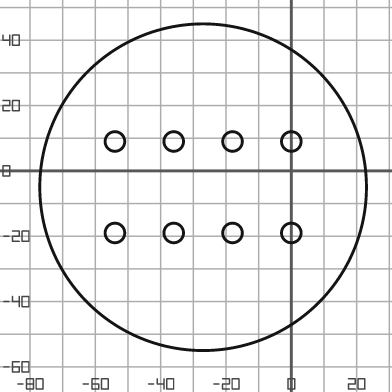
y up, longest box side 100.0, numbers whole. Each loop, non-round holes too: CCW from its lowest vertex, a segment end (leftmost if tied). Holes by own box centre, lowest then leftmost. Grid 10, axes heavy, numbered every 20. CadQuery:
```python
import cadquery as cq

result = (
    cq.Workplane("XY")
    .moveTo(-27.0, -5.0)
    .circle(50.0)
    .moveTo(-54.0, -19.0)
    .circle(3.0)
    .moveTo(-36.0, -19.0)
    .circle(3.0)
    .moveTo(-18.0, -19.0)
    .circle(3.0)
    .moveTo(0.0, -19.0)
    .circle(3.0)
    .moveTo(-54.0, 9.0)
    .circle(3.0)
    .moveTo(-36.0, 9.0)
    .circle(3.0)
    .moveTo(-18.0, 9.0)
    .circle(3.0)
    .moveTo(0.0, 9.0)
    .circle(3.0)
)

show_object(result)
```